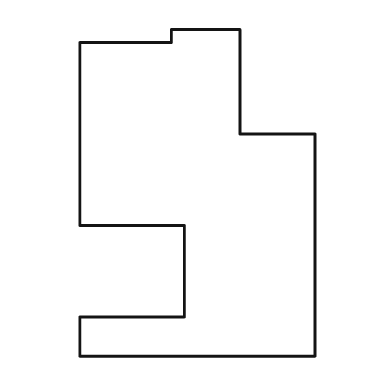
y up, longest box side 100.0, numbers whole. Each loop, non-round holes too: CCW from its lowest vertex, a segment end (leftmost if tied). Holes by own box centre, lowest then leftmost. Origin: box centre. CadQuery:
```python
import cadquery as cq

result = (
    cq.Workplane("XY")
    .moveTo(-36.0, -50.0)
    .lineTo(36.0, -50.0)
    .lineTo(36.0, 18.0)
    .lineTo(13.0, 18.0)
    .lineTo(13.0, 50.0)
    .lineTo(-8.0, 50.0)
    .lineTo(-8.0, 46.0)
    .lineTo(-36.0, 46.0)
    .lineTo(-36.0, -10.0)
    .lineTo(-4.0, -10.0)
    .lineTo(-4.0, -38.0)
    .lineTo(-36.0, -38.0)
    .close()
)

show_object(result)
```